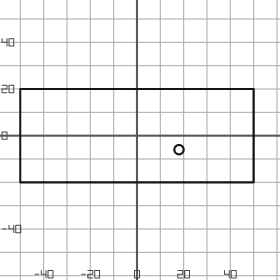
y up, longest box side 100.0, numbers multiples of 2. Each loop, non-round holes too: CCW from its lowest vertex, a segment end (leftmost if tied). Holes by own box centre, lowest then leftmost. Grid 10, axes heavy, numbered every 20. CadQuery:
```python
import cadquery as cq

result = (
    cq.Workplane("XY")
    .moveTo(-50.0, -20.0)
    .lineTo(50.0, -20.0)
    .lineTo(50.0, 20.0)
    .lineTo(-50.0, 20.0)
    .close()
    .moveTo(18.0, -6.0)
    .circle(2.0)
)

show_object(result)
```